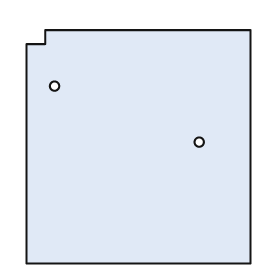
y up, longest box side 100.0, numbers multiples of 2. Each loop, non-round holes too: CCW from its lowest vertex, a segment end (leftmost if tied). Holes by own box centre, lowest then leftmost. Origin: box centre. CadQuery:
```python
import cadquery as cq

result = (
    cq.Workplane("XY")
    .moveTo(-48.0, -50.0)
    .lineTo(48.0, -50.0)
    .lineTo(48.0, 50.0)
    .lineTo(-40.0, 50.0)
    .lineTo(-40.0, 44.0)
    .lineTo(-48.0, 44.0)
    .close()
    .moveTo(26.0, 2.0)
    .circle(2.0)
    .moveTo(-36.0, 26.0)
    .circle(2.0)
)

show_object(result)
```